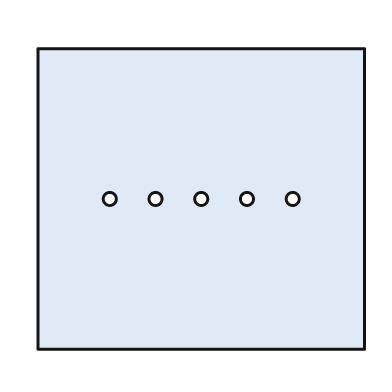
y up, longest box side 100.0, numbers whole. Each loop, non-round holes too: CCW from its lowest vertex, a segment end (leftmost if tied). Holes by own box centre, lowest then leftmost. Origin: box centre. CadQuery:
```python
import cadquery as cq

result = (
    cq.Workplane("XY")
    .moveTo(-50.0, -46.0)
    .lineTo(50.0, -46.0)
    .lineTo(50.0, 46.0)
    .lineTo(-50.0, 46.0)
    .close()
    .moveTo(-28.0, 0.0)
    .circle(2.0)
    .moveTo(-14.0, 0.0)
    .circle(2.0)
    .moveTo(0.0, 0.0)
    .circle(2.0)
    .moveTo(14.0, 0.0)
    .circle(2.0)
    .moveTo(28.0, 0.0)
    .circle(2.0)
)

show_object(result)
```